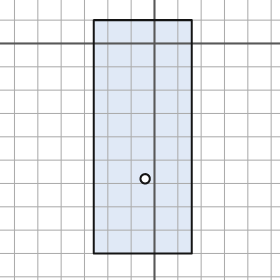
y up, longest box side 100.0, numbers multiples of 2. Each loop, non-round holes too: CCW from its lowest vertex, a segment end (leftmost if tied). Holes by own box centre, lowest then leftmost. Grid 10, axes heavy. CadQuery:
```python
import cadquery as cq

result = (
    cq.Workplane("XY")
    .moveTo(-26.0, -90.0)
    .lineTo(16.0, -90.0)
    .lineTo(16.0, 10.0)
    .lineTo(-26.0, 10.0)
    .close()
    .moveTo(-4.0, -58.0)
    .circle(2.0)
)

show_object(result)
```